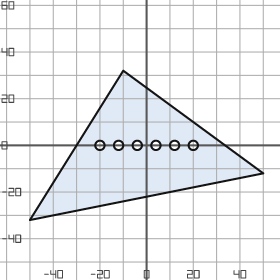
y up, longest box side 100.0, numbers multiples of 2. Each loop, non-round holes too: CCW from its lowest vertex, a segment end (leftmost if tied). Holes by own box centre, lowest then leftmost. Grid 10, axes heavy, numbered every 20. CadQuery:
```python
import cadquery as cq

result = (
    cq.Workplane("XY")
    .moveTo(-50.0, -32.0)
    .lineTo(50.0, -12.0)
    .lineTo(-10.0, 32.0)
    .close()
    .moveTo(-20.0, 0.0)
    .circle(2.0)
    .moveTo(-12.0, 0.0)
    .circle(2.0)
    .moveTo(-4.0, 0.0)
    .circle(2.0)
    .moveTo(4.0, 0.0)
    .circle(2.0)
    .moveTo(12.0, 0.0)
    .circle(2.0)
    .moveTo(20.0, 0.0)
    .circle(2.0)
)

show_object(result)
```